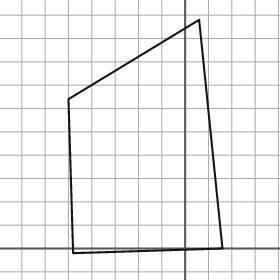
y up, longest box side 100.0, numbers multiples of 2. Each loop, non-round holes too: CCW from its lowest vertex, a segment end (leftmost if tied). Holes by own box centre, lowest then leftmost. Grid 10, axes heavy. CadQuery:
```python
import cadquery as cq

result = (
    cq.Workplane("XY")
    .moveTo(-48.0, -2.0)
    .lineTo(16.0, 0.0)
    .lineTo(6.0, 98.0)
    .lineTo(-50.0, 64.0)
    .close()
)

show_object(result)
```